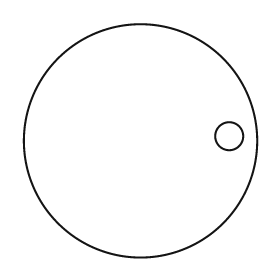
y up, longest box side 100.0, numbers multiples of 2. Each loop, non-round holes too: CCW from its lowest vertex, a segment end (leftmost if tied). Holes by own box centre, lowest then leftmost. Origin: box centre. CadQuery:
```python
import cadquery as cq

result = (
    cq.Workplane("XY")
    .moveTo(0.0, 0.0)
    .circle(50.0)
    .moveTo(38.0, 2.0)
    .circle(6.0)
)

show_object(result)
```